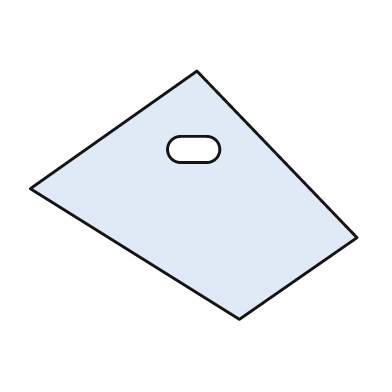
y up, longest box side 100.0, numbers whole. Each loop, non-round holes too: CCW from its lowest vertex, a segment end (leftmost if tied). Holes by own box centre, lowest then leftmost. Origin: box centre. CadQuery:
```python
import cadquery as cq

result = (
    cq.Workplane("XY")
    .moveTo(14.0, -38.0)
    .lineTo(50.0, -13.0)
    .lineTo(1.0, 38.0)
    .lineTo(-50.0, 2.0)
    .close()
    .moveTo(-4.0, 10.0)
    .lineTo(4.0, 10.0)
    .threePointArc((8.0, 14.0), (4.0, 18.0))
    .lineTo(-4.0, 18.0)
    .threePointArc((-8.0, 14.0), (-4.0, 10.0))
    .close()
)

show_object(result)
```